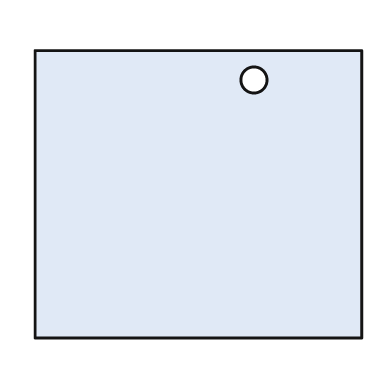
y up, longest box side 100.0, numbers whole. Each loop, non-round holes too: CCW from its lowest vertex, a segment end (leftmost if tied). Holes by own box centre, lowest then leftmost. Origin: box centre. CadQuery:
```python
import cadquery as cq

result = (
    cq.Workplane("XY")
    .moveTo(-50.0, -44.0)
    .lineTo(50.0, -44.0)
    .lineTo(50.0, 44.0)
    .lineTo(-50.0, 44.0)
    .close()
    .moveTo(17.0, 35.0)
    .circle(4.0)
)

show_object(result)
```